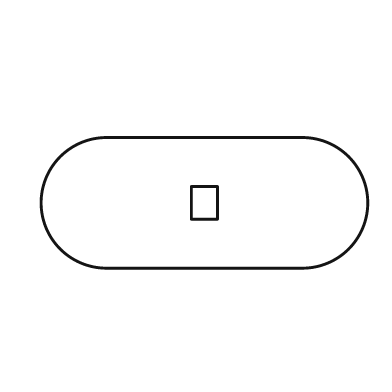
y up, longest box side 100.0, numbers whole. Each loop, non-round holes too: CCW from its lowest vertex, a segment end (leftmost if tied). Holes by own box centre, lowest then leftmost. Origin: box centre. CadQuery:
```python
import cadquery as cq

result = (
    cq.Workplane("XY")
    .moveTo(-30.0, -20.0)
    .lineTo(30.0, -20.0)
    .threePointArc((50.0, 0.0), (30.0, 20.0))
    .lineTo(-30.0, 20.0)
    .threePointArc((-50.0, 0.0), (-30.0, -20.0))
    .close()
    .moveTo(-4.0, -5.0)
    .lineTo(4.0, -5.0)
    .lineTo(4.0, 5.0)
    .lineTo(-4.0, 5.0)
    .close()
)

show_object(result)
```